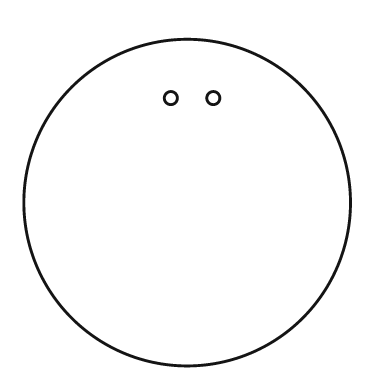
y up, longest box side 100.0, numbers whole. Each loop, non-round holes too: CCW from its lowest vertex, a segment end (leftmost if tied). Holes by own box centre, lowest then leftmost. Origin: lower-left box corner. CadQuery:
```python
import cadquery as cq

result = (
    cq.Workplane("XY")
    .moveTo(50.0, 50.0)
    .circle(50.0)
    .moveTo(45.0, 82.0)
    .circle(2.0)
    .moveTo(58.0, 82.0)
    .circle(2.0)
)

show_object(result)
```